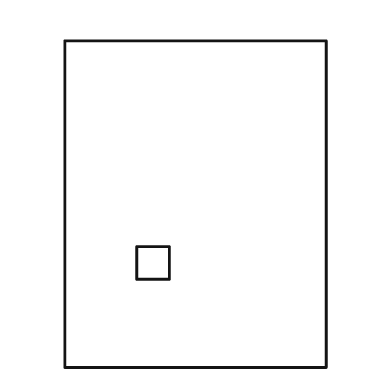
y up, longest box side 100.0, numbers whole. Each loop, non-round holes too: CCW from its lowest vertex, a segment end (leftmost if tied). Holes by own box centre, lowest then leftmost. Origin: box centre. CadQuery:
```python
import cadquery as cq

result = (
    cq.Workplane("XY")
    .moveTo(-40.0, -50.0)
    .lineTo(40.0, -50.0)
    .lineTo(40.0, 50.0)
    .lineTo(-40.0, 50.0)
    .close()
    .moveTo(-18.0, -23.0)
    .lineTo(-8.0, -23.0)
    .lineTo(-8.0, -13.0)
    .lineTo(-18.0, -13.0)
    .close()
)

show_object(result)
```